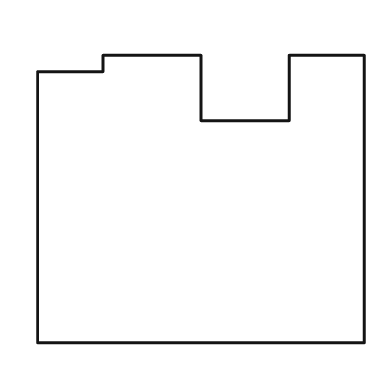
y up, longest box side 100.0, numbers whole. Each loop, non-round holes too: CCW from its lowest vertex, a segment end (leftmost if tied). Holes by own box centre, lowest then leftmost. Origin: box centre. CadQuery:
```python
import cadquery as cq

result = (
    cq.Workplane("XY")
    .moveTo(-50.0, -44.0)
    .lineTo(50.0, -44.0)
    .lineTo(50.0, 44.0)
    .lineTo(27.0, 44.0)
    .lineTo(27.0, 24.0)
    .lineTo(0.0, 24.0)
    .lineTo(0.0, 44.0)
    .lineTo(-30.0, 44.0)
    .lineTo(-30.0, 39.0)
    .lineTo(-50.0, 39.0)
    .close()
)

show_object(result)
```